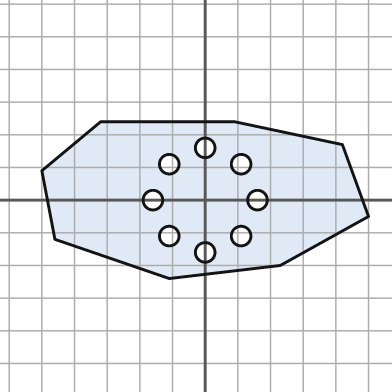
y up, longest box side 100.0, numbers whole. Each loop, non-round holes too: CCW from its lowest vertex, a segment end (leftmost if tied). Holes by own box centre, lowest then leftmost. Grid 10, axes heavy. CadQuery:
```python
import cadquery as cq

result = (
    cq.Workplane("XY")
    .moveTo(-11.0, -24.0)
    .lineTo(23.0, -20.0)
    .lineTo(50.0, -5.0)
    .lineTo(42.0, 17.0)
    .lineTo(9.0, 24.0)
    .lineTo(-32.0, 24.0)
    .lineTo(-50.0, 9.0)
    .lineTo(-46.0, -12.0)
    .close()
    .moveTo(0.0, -16.0)
    .circle(3.0)
    .moveTo(-11.0, -11.0)
    .circle(3.0)
    .moveTo(11.0, -11.0)
    .circle(3.0)
    .moveTo(-16.0, 0.0)
    .circle(3.0)
    .moveTo(16.0, 0.0)
    .circle(3.0)
    .moveTo(-11.0, 11.0)
    .circle(3.0)
    .moveTo(11.0, 11.0)
    .circle(3.0)
    .moveTo(0.0, 16.0)
    .circle(3.0)
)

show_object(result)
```